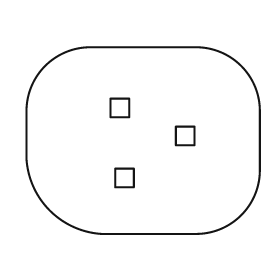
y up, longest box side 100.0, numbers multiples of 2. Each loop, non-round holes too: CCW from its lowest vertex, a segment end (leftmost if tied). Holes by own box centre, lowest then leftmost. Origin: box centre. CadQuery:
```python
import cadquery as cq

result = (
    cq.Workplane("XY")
    .moveTo(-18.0, -40.0)
    .lineTo(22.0, -40.0)
    .threePointArc((42.0, -32.0), (50.0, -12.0))
    .lineTo(50.0, 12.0)
    .threePointArc((42.0, 32.0), (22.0, 40.0))
    .lineTo(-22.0, 40.0)
    .threePointArc((-42.0, 32.0), (-50.0, 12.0))
    .lineTo(-50.0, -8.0)
    .threePointArc((-40.0, -30.0), (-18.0, -40.0))
    .close()
    .moveTo(-12.0, -20.0)
    .lineTo(-4.0, -20.0)
    .lineTo(-4.0, -12.0)
    .lineTo(-12.0, -12.0)
    .close()
    .moveTo(14.0, -2.0)
    .lineTo(22.0, -2.0)
    .lineTo(22.0, 6.0)
    .lineTo(14.0, 6.0)
    .close()
    .moveTo(-14.0, 10.0)
    .lineTo(-6.0, 10.0)
    .lineTo(-6.0, 18.0)
    .lineTo(-14.0, 18.0)
    .close()
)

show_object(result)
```